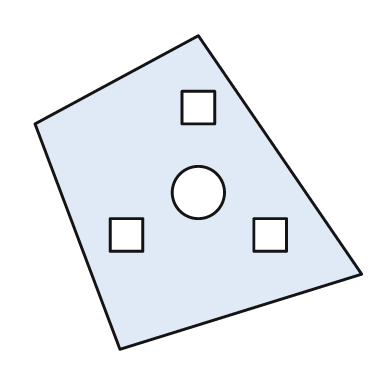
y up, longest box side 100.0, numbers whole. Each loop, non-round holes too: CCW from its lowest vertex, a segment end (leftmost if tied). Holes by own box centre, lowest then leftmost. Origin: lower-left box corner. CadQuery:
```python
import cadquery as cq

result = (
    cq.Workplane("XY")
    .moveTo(26.0, 0.0)
    .lineTo(100.0, 23.0)
    .lineTo(50.0, 96.0)
    .lineTo(0.0, 69.0)
    .close()
    .moveTo(23.0, 30.0)
    .lineTo(33.0, 30.0)
    .lineTo(33.0, 40.0)
    .lineTo(23.0, 40.0)
    .close()
    .moveTo(67.0, 30.0)
    .lineTo(77.0, 30.0)
    .lineTo(77.0, 40.0)
    .lineTo(67.0, 40.0)
    .close()
    .moveTo(50.0, 48.0)
    .circle(8.0)
    .moveTo(45.0, 69.0)
    .lineTo(55.0, 69.0)
    .lineTo(55.0, 79.0)
    .lineTo(45.0, 79.0)
    .close()
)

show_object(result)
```